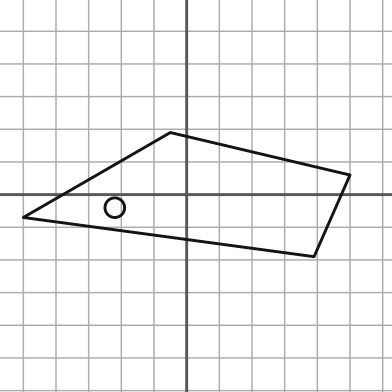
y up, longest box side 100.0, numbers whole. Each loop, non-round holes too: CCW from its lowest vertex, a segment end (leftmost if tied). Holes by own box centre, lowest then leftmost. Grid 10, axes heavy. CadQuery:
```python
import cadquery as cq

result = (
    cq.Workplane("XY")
    .moveTo(39.0, -19.0)
    .lineTo(50.0, 6.0)
    .lineTo(-5.0, 19.0)
    .lineTo(-50.0, -7.0)
    .close()
    .moveTo(-22.0, -4.0)
    .circle(3.0)
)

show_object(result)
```